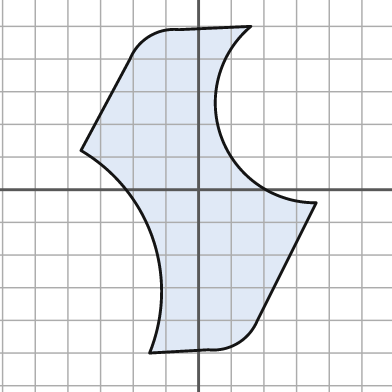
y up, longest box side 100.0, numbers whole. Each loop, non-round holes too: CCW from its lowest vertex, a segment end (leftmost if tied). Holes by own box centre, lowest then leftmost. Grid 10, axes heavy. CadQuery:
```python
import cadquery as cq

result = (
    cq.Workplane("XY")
    .moveTo(-15.0, -50.0)
    .lineTo(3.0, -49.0)
    .threePointArc((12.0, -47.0), (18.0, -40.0))
    .lineTo(36.0, -4.0)
    .threePointArc((7.0, 16.0), (16.0, 50.0))
    .lineTo(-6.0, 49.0)
    .threePointArc((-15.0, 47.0), (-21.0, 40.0))
    .lineTo(-36.0, 12.0)
    .threePointArc((-14.0, -15.0), (-15.0, -50.0))
    .close()
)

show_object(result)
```